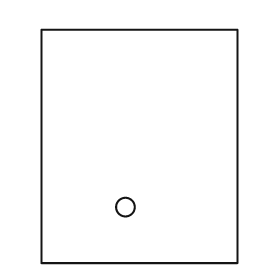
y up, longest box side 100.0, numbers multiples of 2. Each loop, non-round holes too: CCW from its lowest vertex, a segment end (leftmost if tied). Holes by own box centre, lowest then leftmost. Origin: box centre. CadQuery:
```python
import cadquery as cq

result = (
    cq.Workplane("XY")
    .moveTo(-42.0, -50.0)
    .lineTo(42.0, -50.0)
    .lineTo(42.0, 50.0)
    .lineTo(-42.0, 50.0)
    .close()
    .moveTo(-6.0, -26.0)
    .circle(4.0)
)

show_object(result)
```